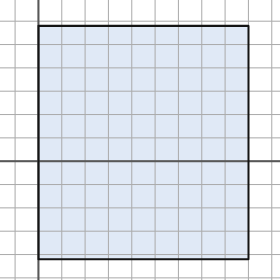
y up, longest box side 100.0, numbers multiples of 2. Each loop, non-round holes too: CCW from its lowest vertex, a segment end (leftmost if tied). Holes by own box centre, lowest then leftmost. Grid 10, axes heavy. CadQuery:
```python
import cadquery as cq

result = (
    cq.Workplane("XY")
    .moveTo(0.0, -42.0)
    .lineTo(90.0, -42.0)
    .lineTo(90.0, 58.0)
    .lineTo(0.0, 58.0)
    .close()
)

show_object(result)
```